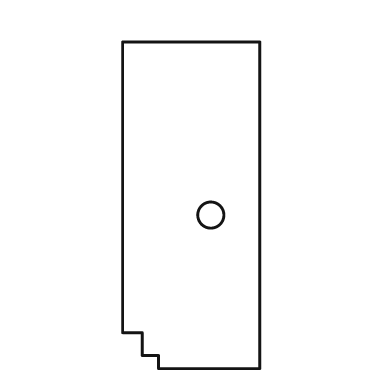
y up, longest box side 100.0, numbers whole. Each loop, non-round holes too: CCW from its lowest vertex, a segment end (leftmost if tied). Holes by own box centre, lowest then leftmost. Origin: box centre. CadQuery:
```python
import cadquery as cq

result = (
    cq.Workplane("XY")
    .moveTo(-10.0, -50.0)
    .lineTo(21.0, -50.0)
    .lineTo(21.0, 50.0)
    .lineTo(-21.0, 50.0)
    .lineTo(-21.0, -39.0)
    .lineTo(-15.0, -39.0)
    .lineTo(-15.0, -46.0)
    .lineTo(-10.0, -46.0)
    .close()
    .moveTo(6.0, -3.0)
    .circle(4.0)
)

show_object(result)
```